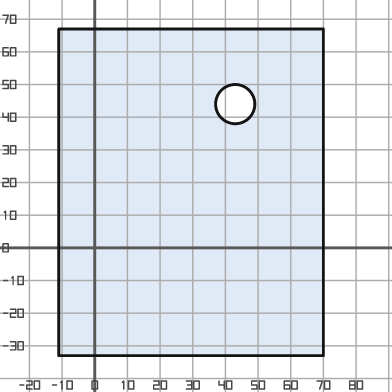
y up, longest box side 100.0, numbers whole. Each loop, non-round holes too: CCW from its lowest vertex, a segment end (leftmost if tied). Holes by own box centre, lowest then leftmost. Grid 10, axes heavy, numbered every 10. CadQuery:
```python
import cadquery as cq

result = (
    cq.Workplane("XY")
    .moveTo(-11.0, -33.0)
    .lineTo(70.0, -33.0)
    .lineTo(70.0, 67.0)
    .lineTo(-11.0, 67.0)
    .close()
    .moveTo(43.0, 44.0)
    .circle(6.0)
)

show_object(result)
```